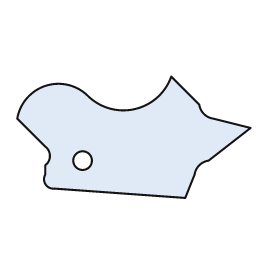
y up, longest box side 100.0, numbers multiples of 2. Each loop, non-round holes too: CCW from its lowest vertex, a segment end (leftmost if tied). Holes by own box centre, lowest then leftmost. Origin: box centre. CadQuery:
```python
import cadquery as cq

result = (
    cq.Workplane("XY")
    .moveTo(22.0, -26.0)
    .lineTo(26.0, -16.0)
    .threePointArc((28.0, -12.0), (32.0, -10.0))
    .lineTo(50.0, 4.0)
    .lineTo(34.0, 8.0)
    .threePointArc((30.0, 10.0), (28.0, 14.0))
    .lineTo(16.0, 26.0)
    .threePointArc((0.0, 12.0), (-20.0, 18.0))
    .threePointArc((-38.0, 22.0), (-50.0, 8.0))
    .lineTo(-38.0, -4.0)
    .threePointArc((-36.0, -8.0), (-38.0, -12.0))
    .lineTo(-38.0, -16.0)
    .threePointArc((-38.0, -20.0), (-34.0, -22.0))
    .close()
    .moveTo(-22.0, -10.0)
    .circle(4.0)
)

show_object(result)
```